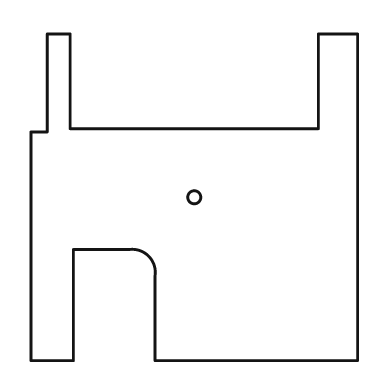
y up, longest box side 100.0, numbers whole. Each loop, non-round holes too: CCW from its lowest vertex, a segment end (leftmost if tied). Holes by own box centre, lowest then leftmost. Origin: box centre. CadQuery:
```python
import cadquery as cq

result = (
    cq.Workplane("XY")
    .moveTo(-50.0, -50.0)
    .lineTo(-37.0, -50.0)
    .lineTo(-37.0, -16.0)
    .lineTo(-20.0, -16.0)
    .threePointArc((-14.0, -18.0), (-12.0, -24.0))
    .lineTo(-12.0, -50.0)
    .lineTo(50.0, -50.0)
    .lineTo(50.0, 50.0)
    .lineTo(38.0, 50.0)
    .lineTo(38.0, 21.0)
    .lineTo(-38.0, 21.0)
    .lineTo(-38.0, 50.0)
    .lineTo(-45.0, 50.0)
    .lineTo(-45.0, 20.0)
    .lineTo(-50.0, 20.0)
    .close()
    .moveTo(0.0, 0.0)
    .circle(2.0)
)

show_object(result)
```